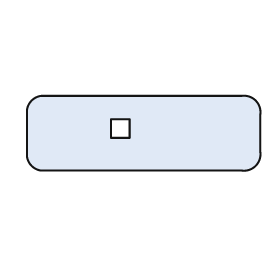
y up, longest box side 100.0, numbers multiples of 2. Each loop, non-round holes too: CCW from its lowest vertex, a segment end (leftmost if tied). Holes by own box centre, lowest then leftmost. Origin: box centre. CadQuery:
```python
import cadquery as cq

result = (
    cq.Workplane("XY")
    .moveTo(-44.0, -16.0)
    .lineTo(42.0, -16.0)
    .threePointArc((48.0, -14.0), (50.0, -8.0))
    .lineTo(50.0, 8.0)
    .threePointArc((48.0, 14.0), (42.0, 16.0))
    .lineTo(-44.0, 16.0)
    .threePointArc((-48.0, 14.0), (-50.0, 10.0))
    .lineTo(-50.0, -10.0)
    .threePointArc((-48.0, -14.0), (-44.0, -16.0))
    .close()
    .moveTo(-14.0, -2.0)
    .lineTo(-6.0, -2.0)
    .lineTo(-6.0, 6.0)
    .lineTo(-14.0, 6.0)
    .close()
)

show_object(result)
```